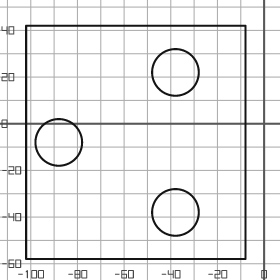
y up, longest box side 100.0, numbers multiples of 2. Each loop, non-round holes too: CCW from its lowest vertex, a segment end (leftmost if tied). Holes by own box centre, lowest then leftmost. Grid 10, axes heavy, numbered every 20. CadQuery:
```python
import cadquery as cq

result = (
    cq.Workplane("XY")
    .moveTo(-102.0, -58.0)
    .lineTo(-8.0, -58.0)
    .lineTo(-8.0, 42.0)
    .lineTo(-102.0, 42.0)
    .close()
    .moveTo(-38.0, -38.0)
    .circle(10.0)
    .moveTo(-88.0, -8.0)
    .circle(10.0)
    .moveTo(-38.0, 22.0)
    .circle(10.0)
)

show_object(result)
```